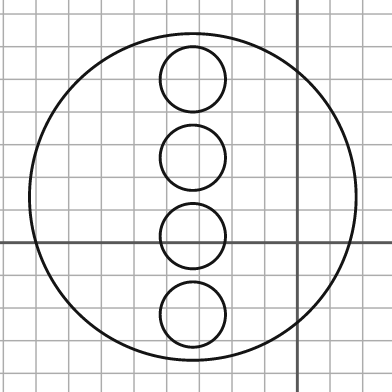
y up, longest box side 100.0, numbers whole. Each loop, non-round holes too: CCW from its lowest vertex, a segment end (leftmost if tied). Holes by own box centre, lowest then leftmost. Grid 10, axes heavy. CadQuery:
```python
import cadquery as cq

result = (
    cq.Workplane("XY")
    .moveTo(-32.0, 14.0)
    .circle(50.0)
    .moveTo(-32.0, -22.0)
    .circle(10.0)
    .moveTo(-32.0, 2.0)
    .circle(10.0)
    .moveTo(-32.0, 26.0)
    .circle(10.0)
    .moveTo(-32.0, 50.0)
    .circle(10.0)
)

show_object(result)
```